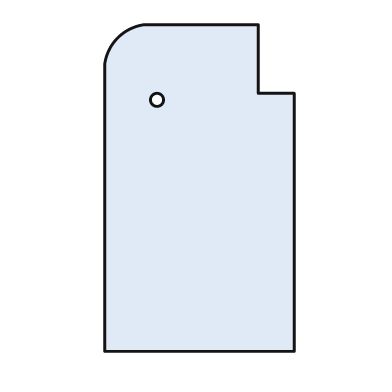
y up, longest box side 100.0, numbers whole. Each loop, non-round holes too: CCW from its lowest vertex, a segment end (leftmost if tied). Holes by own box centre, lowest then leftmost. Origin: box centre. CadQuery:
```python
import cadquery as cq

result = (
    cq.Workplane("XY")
    .moveTo(-29.0, -50.0)
    .lineTo(29.0, -50.0)
    .lineTo(29.0, 29.0)
    .lineTo(18.0, 29.0)
    .lineTo(18.0, 50.0)
    .lineTo(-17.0, 50.0)
    .threePointArc((-25.0, 46.0), (-29.0, 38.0))
    .close()
    .moveTo(-13.0, 27.0)
    .circle(2.0)
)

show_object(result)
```